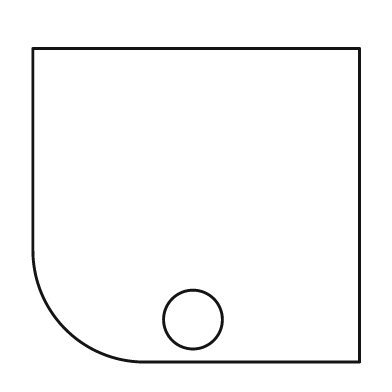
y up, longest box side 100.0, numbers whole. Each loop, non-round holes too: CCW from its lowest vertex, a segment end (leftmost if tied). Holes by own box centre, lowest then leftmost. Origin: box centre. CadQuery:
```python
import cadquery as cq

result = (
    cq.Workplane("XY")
    .moveTo(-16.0, -48.0)
    .lineTo(50.0, -48.0)
    .lineTo(50.0, 48.0)
    .lineTo(-50.0, 48.0)
    .lineTo(-50.0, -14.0)
    .threePointArc((-40.0, -38.0), (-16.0, -48.0))
    .close()
    .moveTo(-1.0, -35.0)
    .circle(9.0)
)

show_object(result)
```